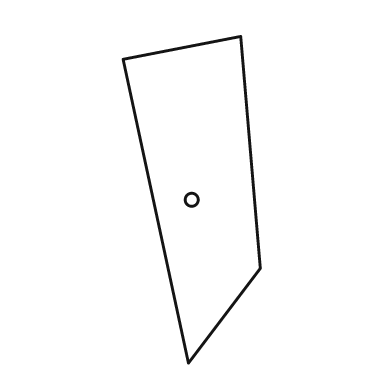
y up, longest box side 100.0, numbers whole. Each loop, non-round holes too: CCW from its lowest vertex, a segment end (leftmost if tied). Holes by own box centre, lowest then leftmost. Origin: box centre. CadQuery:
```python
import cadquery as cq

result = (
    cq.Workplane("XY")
    .moveTo(-1.0, -50.0)
    .lineTo(21.0, -21.0)
    .lineTo(15.0, 50.0)
    .lineTo(-21.0, 43.0)
    .close()
    .moveTo(0.0, 0.0)
    .circle(2.0)
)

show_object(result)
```